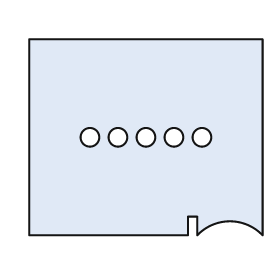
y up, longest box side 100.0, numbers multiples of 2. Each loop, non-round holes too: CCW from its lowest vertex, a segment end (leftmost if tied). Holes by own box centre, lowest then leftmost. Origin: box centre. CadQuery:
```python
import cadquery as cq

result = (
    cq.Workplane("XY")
    .moveTo(-50.0, -42.0)
    .lineTo(18.0, -42.0)
    .lineTo(18.0, -34.0)
    .lineTo(22.0, -34.0)
    .lineTo(22.0, -42.0)
    .threePointArc((36.0, -36.0), (50.0, -42.0))
    .lineTo(50.0, 42.0)
    .lineTo(-50.0, 42.0)
    .close()
    .moveTo(-24.0, 0.0)
    .circle(4.0)
    .moveTo(-12.0, 0.0)
    .circle(4.0)
    .moveTo(0.0, 0.0)
    .circle(4.0)
    .moveTo(12.0, 0.0)
    .circle(4.0)
    .moveTo(24.0, 0.0)
    .circle(4.0)
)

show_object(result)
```